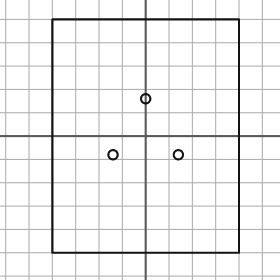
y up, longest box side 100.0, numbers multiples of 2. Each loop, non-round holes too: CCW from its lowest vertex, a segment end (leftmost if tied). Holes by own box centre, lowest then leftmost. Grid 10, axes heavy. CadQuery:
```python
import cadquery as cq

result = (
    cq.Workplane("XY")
    .moveTo(-40.0, -50.0)
    .lineTo(40.0, -50.0)
    .lineTo(40.0, 50.0)
    .lineTo(-40.0, 50.0)
    .close()
    .moveTo(-14.0, -8.0)
    .circle(2.0)
    .moveTo(14.0, -8.0)
    .circle(2.0)
    .moveTo(0.0, 16.0)
    .circle(2.0)
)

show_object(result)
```